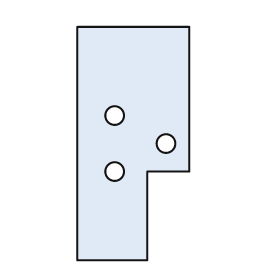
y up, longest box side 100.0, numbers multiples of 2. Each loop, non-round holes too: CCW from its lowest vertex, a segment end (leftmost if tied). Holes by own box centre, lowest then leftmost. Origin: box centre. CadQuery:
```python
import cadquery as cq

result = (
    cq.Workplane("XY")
    .moveTo(-24.0, -50.0)
    .lineTo(6.0, -50.0)
    .lineTo(6.0, -12.0)
    .lineTo(24.0, -12.0)
    .lineTo(24.0, 50.0)
    .lineTo(-24.0, 50.0)
    .close()
    .moveTo(-8.0, -12.0)
    .circle(4.0)
    .moveTo(14.0, 0.0)
    .circle(4.0)
    .moveTo(-8.0, 12.0)
    .circle(4.0)
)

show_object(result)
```